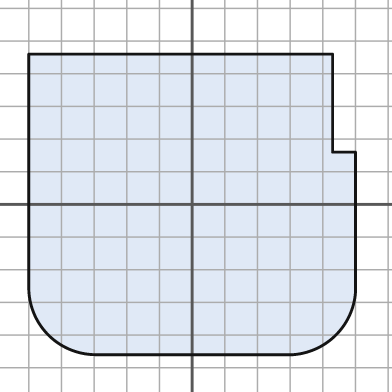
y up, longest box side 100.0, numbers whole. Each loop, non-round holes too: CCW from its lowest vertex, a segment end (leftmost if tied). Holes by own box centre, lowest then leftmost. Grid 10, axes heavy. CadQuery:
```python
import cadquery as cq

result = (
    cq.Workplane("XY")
    .moveTo(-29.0, -46.0)
    .lineTo(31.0, -46.0)
    .threePointArc((44.0, -40.0), (50.0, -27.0))
    .lineTo(50.0, 16.0)
    .lineTo(43.0, 16.0)
    .lineTo(43.0, 46.0)
    .lineTo(-50.0, 46.0)
    .lineTo(-50.0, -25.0)
    .threePointArc((-44.0, -40.0), (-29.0, -46.0))
    .close()
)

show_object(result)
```